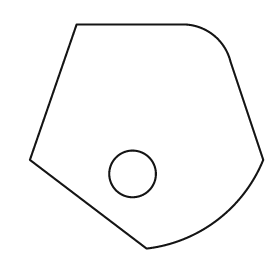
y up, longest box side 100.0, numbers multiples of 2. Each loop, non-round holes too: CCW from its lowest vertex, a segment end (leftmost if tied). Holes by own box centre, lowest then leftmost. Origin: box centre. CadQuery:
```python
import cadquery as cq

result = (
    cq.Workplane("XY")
    .moveTo(0.0, -48.0)
    .threePointArc((30.0, -36.0), (50.0, -10.0))
    .lineTo(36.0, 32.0)
    .threePointArc((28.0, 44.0), (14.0, 48.0))
    .lineTo(-30.0, 48.0)
    .lineTo(-50.0, -10.0)
    .close()
    .moveTo(-6.0, -16.0)
    .circle(10.0)
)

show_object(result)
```